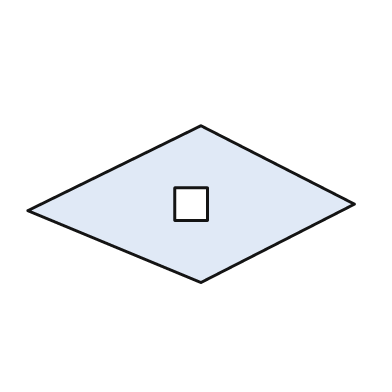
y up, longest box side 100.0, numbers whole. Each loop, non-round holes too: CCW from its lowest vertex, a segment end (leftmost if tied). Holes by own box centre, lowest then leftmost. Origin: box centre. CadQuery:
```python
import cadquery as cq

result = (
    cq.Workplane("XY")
    .moveTo(3.0, -24.0)
    .lineTo(50.0, 0.0)
    .lineTo(3.0, 24.0)
    .lineTo(-50.0, -2.0)
    .close()
    .moveTo(-5.0, -5.0)
    .lineTo(5.0, -5.0)
    .lineTo(5.0, 5.0)
    .lineTo(-5.0, 5.0)
    .close()
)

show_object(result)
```